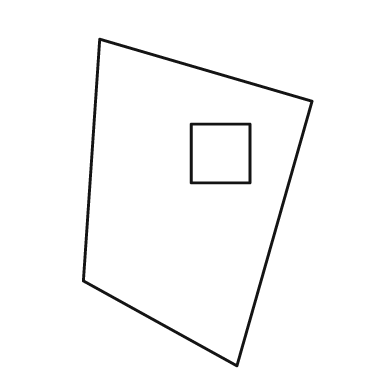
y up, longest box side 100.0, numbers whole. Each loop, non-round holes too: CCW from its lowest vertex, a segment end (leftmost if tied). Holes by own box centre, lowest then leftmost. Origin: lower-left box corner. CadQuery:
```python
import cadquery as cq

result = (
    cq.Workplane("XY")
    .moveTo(47.0, 0.0)
    .lineTo(70.0, 81.0)
    .lineTo(5.0, 100.0)
    .lineTo(0.0, 26.0)
    .close()
    .moveTo(33.0, 56.0)
    .lineTo(51.0, 56.0)
    .lineTo(51.0, 74.0)
    .lineTo(33.0, 74.0)
    .close()
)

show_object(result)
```